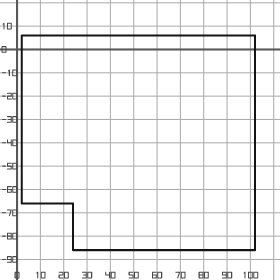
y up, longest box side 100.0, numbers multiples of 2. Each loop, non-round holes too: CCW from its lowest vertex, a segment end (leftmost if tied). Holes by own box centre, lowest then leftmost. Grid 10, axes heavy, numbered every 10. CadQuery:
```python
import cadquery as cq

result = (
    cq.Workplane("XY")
    .moveTo(24.0, -86.0)
    .lineTo(102.0, -86.0)
    .lineTo(102.0, 6.0)
    .lineTo(2.0, 6.0)
    .lineTo(2.0, -66.0)
    .lineTo(24.0, -66.0)
    .close()
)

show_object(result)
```